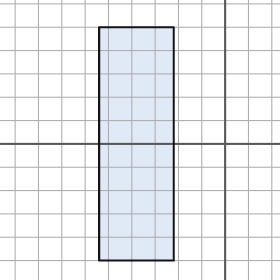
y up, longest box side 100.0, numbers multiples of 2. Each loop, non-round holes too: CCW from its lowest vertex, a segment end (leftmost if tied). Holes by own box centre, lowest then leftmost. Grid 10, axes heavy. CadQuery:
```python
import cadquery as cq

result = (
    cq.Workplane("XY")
    .moveTo(-54.0, -50.0)
    .lineTo(-22.0, -50.0)
    .lineTo(-22.0, 50.0)
    .lineTo(-54.0, 50.0)
    .close()
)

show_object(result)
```